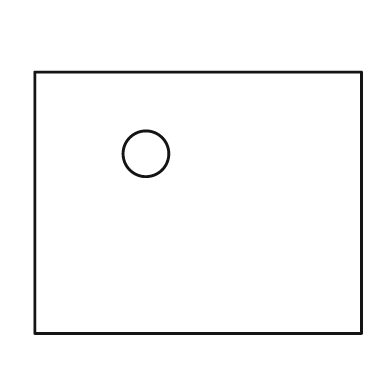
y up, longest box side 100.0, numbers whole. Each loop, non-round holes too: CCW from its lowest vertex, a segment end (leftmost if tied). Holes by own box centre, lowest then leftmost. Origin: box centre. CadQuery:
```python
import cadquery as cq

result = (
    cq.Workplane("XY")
    .moveTo(-50.0, -40.0)
    .lineTo(50.0, -40.0)
    .lineTo(50.0, 40.0)
    .lineTo(-50.0, 40.0)
    .close()
    .moveTo(-16.0, 15.0)
    .circle(7.0)
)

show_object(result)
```